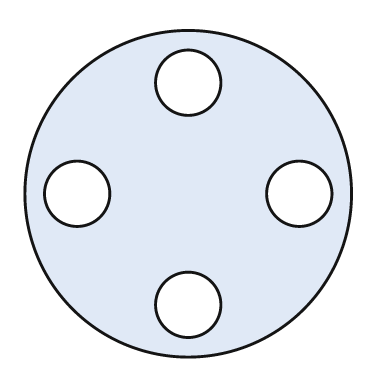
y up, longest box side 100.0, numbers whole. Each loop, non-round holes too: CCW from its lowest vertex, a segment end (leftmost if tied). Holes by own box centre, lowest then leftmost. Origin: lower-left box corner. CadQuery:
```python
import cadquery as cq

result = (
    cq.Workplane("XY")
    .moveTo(50.0, 50.0)
    .circle(50.0)
    .moveTo(50.0, 16.0)
    .circle(10.0)
    .moveTo(16.0, 50.0)
    .circle(10.0)
    .moveTo(84.0, 50.0)
    .circle(10.0)
    .moveTo(50.0, 84.0)
    .circle(10.0)
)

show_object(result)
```